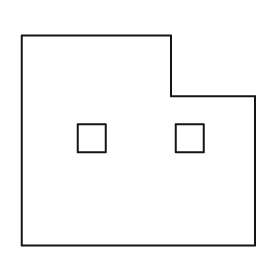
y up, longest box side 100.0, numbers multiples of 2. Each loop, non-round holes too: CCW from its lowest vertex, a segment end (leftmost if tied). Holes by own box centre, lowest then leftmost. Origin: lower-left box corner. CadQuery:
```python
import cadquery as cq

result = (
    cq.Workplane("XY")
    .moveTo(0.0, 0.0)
    .lineTo(100.0, 0.0)
    .lineTo(100.0, 64.0)
    .lineTo(64.0, 64.0)
    .lineTo(64.0, 90.0)
    .lineTo(0.0, 90.0)
    .close()
    .moveTo(24.0, 40.0)
    .lineTo(36.0, 40.0)
    .lineTo(36.0, 52.0)
    .lineTo(24.0, 52.0)
    .close()
    .moveTo(66.0, 40.0)
    .lineTo(78.0, 40.0)
    .lineTo(78.0, 52.0)
    .lineTo(66.0, 52.0)
    .close()
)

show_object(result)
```